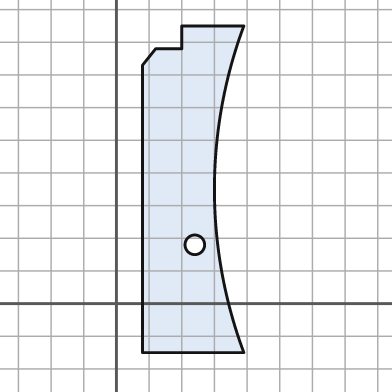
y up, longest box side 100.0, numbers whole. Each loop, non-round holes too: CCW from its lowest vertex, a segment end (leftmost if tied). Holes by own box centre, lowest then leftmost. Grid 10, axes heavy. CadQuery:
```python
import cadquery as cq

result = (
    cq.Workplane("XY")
    .moveTo(8.0, -15.0)
    .lineTo(39.0, -15.0)
    .threePointArc((30.0, 35.0), (39.0, 85.0))
    .lineTo(20.0, 85.0)
    .lineTo(20.0, 78.0)
    .lineTo(12.0, 78.0)
    .lineTo(8.0, 73.0)
    .close()
    .moveTo(24.0, 18.0)
    .circle(3.0)
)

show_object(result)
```